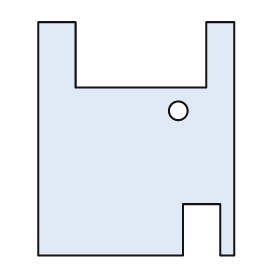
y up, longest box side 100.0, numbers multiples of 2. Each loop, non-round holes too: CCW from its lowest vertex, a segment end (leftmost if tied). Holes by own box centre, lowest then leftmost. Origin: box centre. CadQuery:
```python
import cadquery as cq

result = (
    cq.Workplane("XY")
    .moveTo(-42.0, -50.0)
    .lineTo(20.0, -50.0)
    .lineTo(20.0, -28.0)
    .lineTo(36.0, -28.0)
    .lineTo(36.0, -50.0)
    .lineTo(42.0, -50.0)
    .lineTo(42.0, 50.0)
    .lineTo(30.0, 50.0)
    .lineTo(30.0, 22.0)
    .lineTo(-26.0, 22.0)
    .lineTo(-26.0, 50.0)
    .lineTo(-42.0, 50.0)
    .close()
    .moveTo(18.0, 12.0)
    .circle(4.0)
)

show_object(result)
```